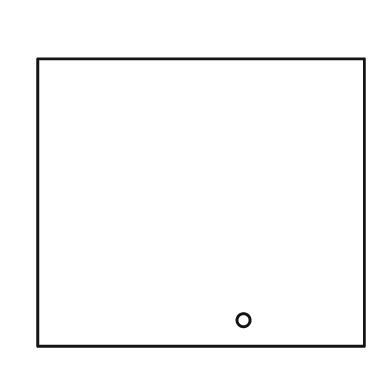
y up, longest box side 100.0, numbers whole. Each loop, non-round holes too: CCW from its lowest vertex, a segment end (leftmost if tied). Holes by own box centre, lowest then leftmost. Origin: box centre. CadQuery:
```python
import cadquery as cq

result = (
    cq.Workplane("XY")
    .moveTo(-50.0, -44.0)
    .lineTo(50.0, -44.0)
    .lineTo(50.0, 44.0)
    .lineTo(-50.0, 44.0)
    .close()
    .moveTo(13.0, -36.0)
    .circle(2.0)
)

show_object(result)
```